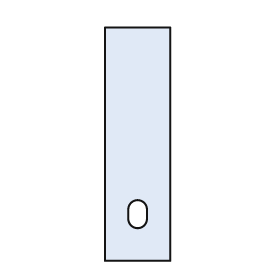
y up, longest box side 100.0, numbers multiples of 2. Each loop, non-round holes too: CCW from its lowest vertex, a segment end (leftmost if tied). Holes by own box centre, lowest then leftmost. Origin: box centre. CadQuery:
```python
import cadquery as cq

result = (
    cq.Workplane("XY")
    .moveTo(-14.0, -50.0)
    .lineTo(14.0, -50.0)
    .lineTo(14.0, 50.0)
    .lineTo(-14.0, 50.0)
    .close()
    .moveTo(-4.0, -32.0)
    .threePointArc((0.0, -36.0), (4.0, -32.0))
    .lineTo(4.0, -28.0)
    .threePointArc((0.0, -24.0), (-4.0, -28.0))
    .close()
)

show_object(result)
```